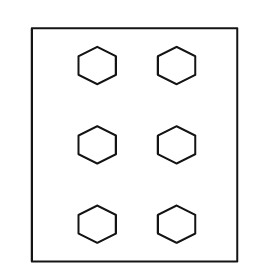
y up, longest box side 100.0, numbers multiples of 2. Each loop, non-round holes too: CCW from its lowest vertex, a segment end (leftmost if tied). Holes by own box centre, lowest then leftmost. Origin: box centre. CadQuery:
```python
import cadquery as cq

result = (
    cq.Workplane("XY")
    .moveTo(-44.0, -50.0)
    .lineTo(44.0, -50.0)
    .lineTo(44.0, 50.0)
    .lineTo(-44.0, 50.0)
    .close()
    .moveTo(-16.0, -42.0)
    .lineTo(-8.0, -38.0)
    .lineTo(-8.0, -30.0)
    .lineTo(-16.0, -26.0)
    .lineTo(-24.0, -30.0)
    .lineTo(-24.0, -38.0)
    .close()
    .moveTo(18.0, -42.0)
    .lineTo(26.0, -38.0)
    .lineTo(26.0, -30.0)
    .lineTo(18.0, -26.0)
    .lineTo(10.0, -30.0)
    .lineTo(10.0, -38.0)
    .close()
    .moveTo(-16.0, -8.0)
    .lineTo(-8.0, -4.0)
    .lineTo(-8.0, 4.0)
    .lineTo(-16.0, 8.0)
    .lineTo(-24.0, 4.0)
    .lineTo(-24.0, -4.0)
    .close()
    .moveTo(18.0, -8.0)
    .lineTo(26.0, -4.0)
    .lineTo(26.0, 4.0)
    .lineTo(18.0, 8.0)
    .lineTo(10.0, 4.0)
    .lineTo(10.0, -4.0)
    .close()
    .moveTo(-16.0, 26.0)
    .lineTo(-8.0, 30.0)
    .lineTo(-8.0, 38.0)
    .lineTo(-16.0, 42.0)
    .lineTo(-24.0, 38.0)
    .lineTo(-24.0, 30.0)
    .close()
    .moveTo(18.0, 26.0)
    .lineTo(26.0, 30.0)
    .lineTo(26.0, 38.0)
    .lineTo(18.0, 42.0)
    .lineTo(10.0, 38.0)
    .lineTo(10.0, 30.0)
    .close()
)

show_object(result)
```